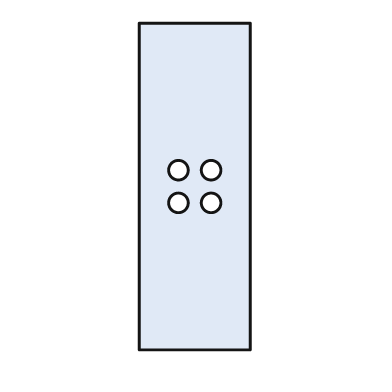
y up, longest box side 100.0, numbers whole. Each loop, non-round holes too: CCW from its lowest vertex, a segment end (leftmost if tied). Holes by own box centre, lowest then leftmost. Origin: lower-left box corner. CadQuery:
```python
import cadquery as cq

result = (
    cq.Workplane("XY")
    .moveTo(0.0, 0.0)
    .lineTo(34.0, 0.0)
    .lineTo(34.0, 100.0)
    .lineTo(0.0, 100.0)
    .close()
    .moveTo(12.0, 45.0)
    .circle(3.0)
    .moveTo(22.0, 45.0)
    .circle(3.0)
    .moveTo(12.0, 55.0)
    .circle(3.0)
    .moveTo(22.0, 55.0)
    .circle(3.0)
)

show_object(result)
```